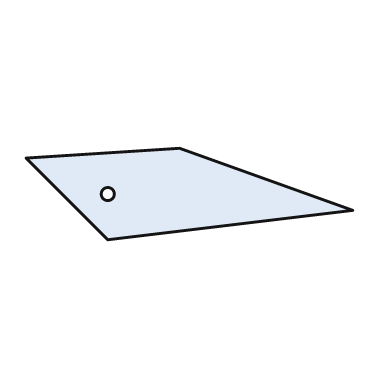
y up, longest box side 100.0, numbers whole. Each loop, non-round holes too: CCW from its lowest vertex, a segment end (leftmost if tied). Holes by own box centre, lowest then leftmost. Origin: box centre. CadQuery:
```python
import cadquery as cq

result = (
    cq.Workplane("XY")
    .moveTo(-25.0, -14.0)
    .lineTo(50.0, -5.0)
    .lineTo(-3.0, 14.0)
    .lineTo(-50.0, 11.0)
    .close()
    .moveTo(-25.0, 0.0)
    .circle(2.0)
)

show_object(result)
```